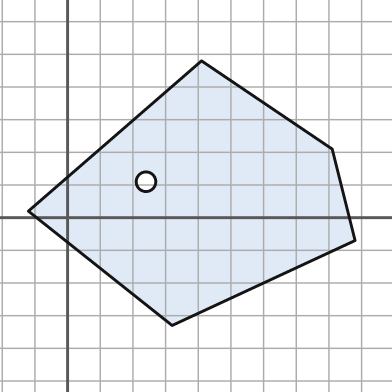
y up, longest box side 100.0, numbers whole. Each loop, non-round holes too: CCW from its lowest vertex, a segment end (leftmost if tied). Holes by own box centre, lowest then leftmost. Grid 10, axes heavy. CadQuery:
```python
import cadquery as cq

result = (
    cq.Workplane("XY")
    .moveTo(32.0, -33.0)
    .lineTo(88.0, -7.0)
    .lineTo(81.0, 21.0)
    .lineTo(41.0, 48.0)
    .lineTo(-12.0, 2.0)
    .close()
    .moveTo(24.0, 11.0)
    .circle(3.0)
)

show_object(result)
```